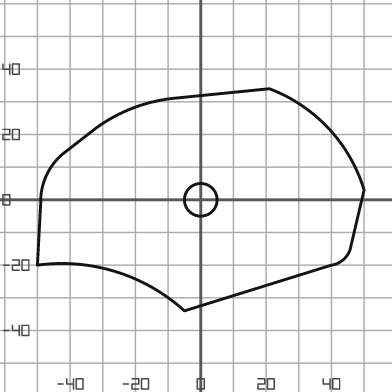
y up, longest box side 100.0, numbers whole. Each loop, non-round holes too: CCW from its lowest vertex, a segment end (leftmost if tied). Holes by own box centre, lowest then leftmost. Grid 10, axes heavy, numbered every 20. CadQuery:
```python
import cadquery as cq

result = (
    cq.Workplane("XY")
    .moveTo(-5.0, -34.0)
    .lineTo(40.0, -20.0)
    .threePointArc((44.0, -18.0), (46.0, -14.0))
    .lineTo(50.0, 3.0)
    .threePointArc((39.0, 22.0), (21.0, 34.0))
    .lineTo(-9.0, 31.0)
    .threePointArc((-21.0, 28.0), (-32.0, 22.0))
    .lineTo(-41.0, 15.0)
    .threePointArc((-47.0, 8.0), (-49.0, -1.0))
    .lineTo(-50.0, -20.0)
    .threePointArc((-26.0, -22.0), (-5.0, -34.0))
    .close()
    .moveTo(0.0, 0.0)
    .circle(5.0)
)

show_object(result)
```